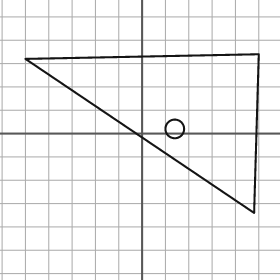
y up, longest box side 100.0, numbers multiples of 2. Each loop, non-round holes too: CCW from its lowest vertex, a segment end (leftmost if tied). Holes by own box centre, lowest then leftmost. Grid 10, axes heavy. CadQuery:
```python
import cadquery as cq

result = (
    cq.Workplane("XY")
    .moveTo(48.0, -34.0)
    .lineTo(50.0, 34.0)
    .lineTo(-50.0, 32.0)
    .close()
    .moveTo(14.0, 2.0)
    .circle(4.0)
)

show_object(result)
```